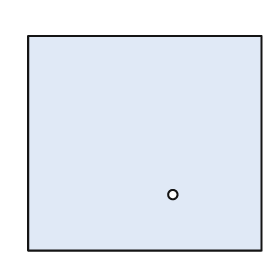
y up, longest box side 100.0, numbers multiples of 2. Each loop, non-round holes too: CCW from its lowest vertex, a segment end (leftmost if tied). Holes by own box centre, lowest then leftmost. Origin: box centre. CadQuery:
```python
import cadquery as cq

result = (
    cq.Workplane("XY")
    .moveTo(-50.0, -46.0)
    .lineTo(50.0, -46.0)
    .lineTo(50.0, 46.0)
    .lineTo(-50.0, 46.0)
    .close()
    .moveTo(12.0, -22.0)
    .circle(2.0)
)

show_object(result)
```